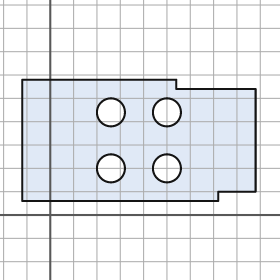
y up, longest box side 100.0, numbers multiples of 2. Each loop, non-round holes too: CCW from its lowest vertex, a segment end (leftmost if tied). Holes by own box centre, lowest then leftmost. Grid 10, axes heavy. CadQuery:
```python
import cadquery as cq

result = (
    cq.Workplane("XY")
    .moveTo(-12.0, 6.0)
    .lineTo(72.0, 6.0)
    .lineTo(72.0, 10.0)
    .lineTo(88.0, 10.0)
    .lineTo(88.0, 54.0)
    .lineTo(54.0, 54.0)
    .lineTo(54.0, 58.0)
    .lineTo(-12.0, 58.0)
    .close()
    .moveTo(26.0, 20.0)
    .circle(6.0)
    .moveTo(50.0, 20.0)
    .circle(6.0)
    .moveTo(26.0, 44.0)
    .circle(6.0)
    .moveTo(50.0, 44.0)
    .circle(6.0)
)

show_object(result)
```